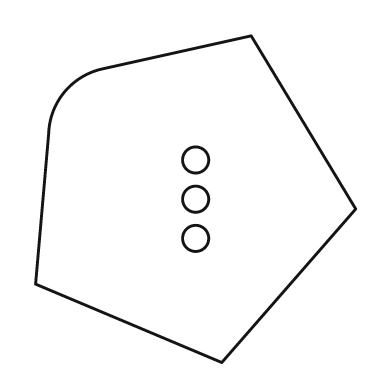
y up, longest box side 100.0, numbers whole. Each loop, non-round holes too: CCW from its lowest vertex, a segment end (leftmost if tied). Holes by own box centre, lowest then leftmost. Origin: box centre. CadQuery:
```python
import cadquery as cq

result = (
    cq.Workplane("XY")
    .moveTo(8.0, -50.0)
    .lineTo(49.0, -3.0)
    .lineTo(17.0, 50.0)
    .lineTo(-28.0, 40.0)
    .threePointArc((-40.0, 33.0), (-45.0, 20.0))
    .lineTo(-49.0, -26.0)
    .close()
    .moveTo(0.0, -12.0)
    .circle(4.0)
    .moveTo(0.0, 0.0)
    .circle(4.0)
    .moveTo(0.0, 12.0)
    .circle(4.0)
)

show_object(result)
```